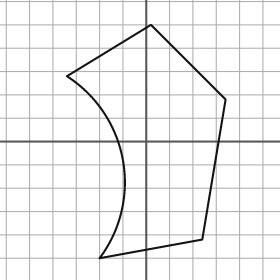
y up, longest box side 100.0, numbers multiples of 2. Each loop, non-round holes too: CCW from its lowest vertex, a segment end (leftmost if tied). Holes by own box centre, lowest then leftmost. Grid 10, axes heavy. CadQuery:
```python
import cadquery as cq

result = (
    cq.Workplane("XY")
    .moveTo(-20.0, -50.0)
    .lineTo(24.0, -42.0)
    .lineTo(34.0, 18.0)
    .lineTo(2.0, 50.0)
    .lineTo(-34.0, 28.0)
    .threePointArc((-10.0, -8.0), (-20.0, -50.0))
    .close()
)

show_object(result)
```